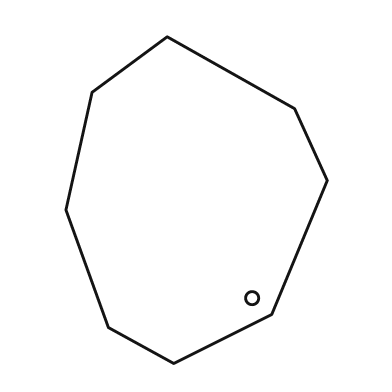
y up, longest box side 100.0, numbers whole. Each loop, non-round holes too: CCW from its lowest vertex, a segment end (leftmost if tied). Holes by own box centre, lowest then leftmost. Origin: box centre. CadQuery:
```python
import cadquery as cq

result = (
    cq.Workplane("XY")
    .moveTo(-7.0, -50.0)
    .lineTo(23.0, -35.0)
    .lineTo(40.0, 6.0)
    .lineTo(30.0, 28.0)
    .lineTo(-9.0, 50.0)
    .lineTo(-32.0, 33.0)
    .lineTo(-40.0, -3.0)
    .lineTo(-27.0, -39.0)
    .close()
    .moveTo(17.0, -30.0)
    .circle(2.0)
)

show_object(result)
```